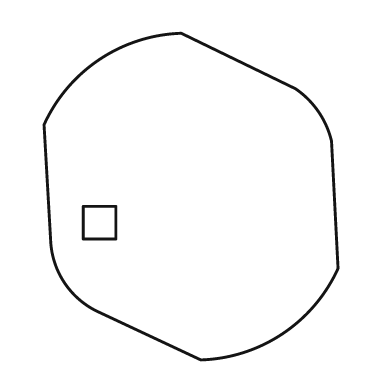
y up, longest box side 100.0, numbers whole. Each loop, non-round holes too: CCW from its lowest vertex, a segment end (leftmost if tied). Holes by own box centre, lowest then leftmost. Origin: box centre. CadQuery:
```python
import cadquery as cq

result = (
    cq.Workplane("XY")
    .moveTo(3.0, -50.0)
    .threePointArc((28.0, -42.0), (45.0, -22.0))
    .lineTo(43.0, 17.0)
    .threePointArc((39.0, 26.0), (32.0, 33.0))
    .lineTo(-3.0, 50.0)
    .threePointArc((-28.0, 42.0), (-45.0, 22.0))
    .lineTo(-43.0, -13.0)
    .threePointArc((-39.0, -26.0), (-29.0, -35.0))
    .close()
    .moveTo(-33.0, -13.0)
    .lineTo(-23.0, -13.0)
    .lineTo(-23.0, -3.0)
    .lineTo(-33.0, -3.0)
    .close()
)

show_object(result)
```